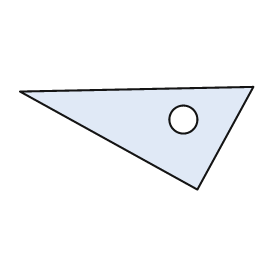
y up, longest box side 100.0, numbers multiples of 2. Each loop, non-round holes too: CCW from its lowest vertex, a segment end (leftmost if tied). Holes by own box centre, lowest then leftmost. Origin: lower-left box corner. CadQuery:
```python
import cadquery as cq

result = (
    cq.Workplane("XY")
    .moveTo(76.0, 0.0)
    .lineTo(100.0, 44.0)
    .lineTo(0.0, 42.0)
    .close()
    .moveTo(70.0, 30.0)
    .circle(6.0)
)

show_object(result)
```